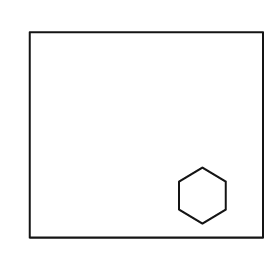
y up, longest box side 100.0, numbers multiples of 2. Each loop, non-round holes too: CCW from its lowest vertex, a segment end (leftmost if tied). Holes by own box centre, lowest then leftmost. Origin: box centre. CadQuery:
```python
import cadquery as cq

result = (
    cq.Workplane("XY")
    .moveTo(-50.0, -44.0)
    .lineTo(50.0, -44.0)
    .lineTo(50.0, 44.0)
    .lineTo(-50.0, 44.0)
    .close()
    .moveTo(24.0, -38.0)
    .lineTo(34.0, -32.0)
    .lineTo(34.0, -20.0)
    .lineTo(24.0, -14.0)
    .lineTo(14.0, -20.0)
    .lineTo(14.0, -32.0)
    .close()
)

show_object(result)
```